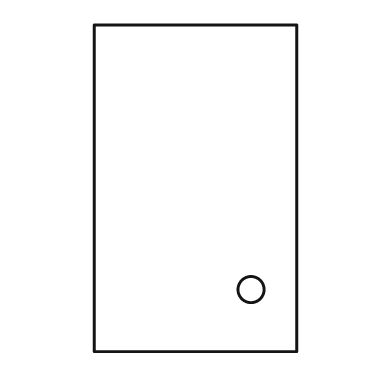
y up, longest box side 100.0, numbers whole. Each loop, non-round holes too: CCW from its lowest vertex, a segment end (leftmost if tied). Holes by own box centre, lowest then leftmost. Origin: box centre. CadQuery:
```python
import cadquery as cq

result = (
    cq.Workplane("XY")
    .moveTo(-31.0, -50.0)
    .lineTo(31.0, -50.0)
    .lineTo(31.0, 50.0)
    .lineTo(-31.0, 50.0)
    .close()
    .moveTo(17.0, -31.0)
    .circle(4.0)
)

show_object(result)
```